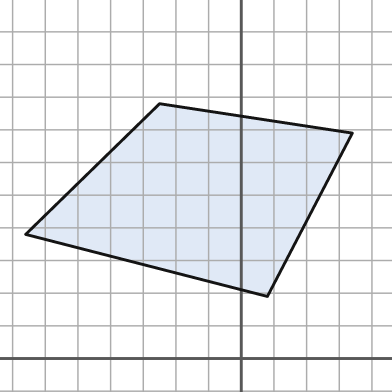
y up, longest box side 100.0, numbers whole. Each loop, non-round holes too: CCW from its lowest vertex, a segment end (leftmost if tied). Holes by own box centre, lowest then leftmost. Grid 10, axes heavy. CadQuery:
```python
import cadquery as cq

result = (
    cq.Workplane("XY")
    .moveTo(8.0, 19.0)
    .lineTo(34.0, 69.0)
    .lineTo(-25.0, 78.0)
    .lineTo(-66.0, 38.0)
    .close()
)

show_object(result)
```